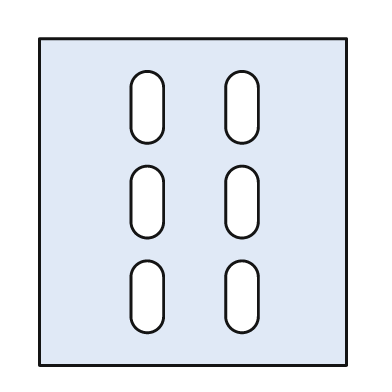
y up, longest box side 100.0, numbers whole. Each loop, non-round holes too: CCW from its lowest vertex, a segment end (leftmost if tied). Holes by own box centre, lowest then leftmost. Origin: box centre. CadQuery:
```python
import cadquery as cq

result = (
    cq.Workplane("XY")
    .moveTo(-47.0, -50.0)
    .lineTo(47.0, -50.0)
    .lineTo(47.0, 50.0)
    .lineTo(-47.0, 50.0)
    .close()
    .moveTo(-19.0, -35.0)
    .threePointArc((-14.0, -40.0), (-9.0, -35.0))
    .lineTo(-9.0, -23.0)
    .threePointArc((-14.0, -18.0), (-19.0, -23.0))
    .close()
    .moveTo(10.0, -35.0)
    .threePointArc((15.0, -40.0), (20.0, -35.0))
    .lineTo(20.0, -23.0)
    .threePointArc((15.0, -18.0), (10.0, -23.0))
    .close()
    .moveTo(-19.0, -6.0)
    .threePointArc((-14.0, -11.0), (-9.0, -6.0))
    .lineTo(-9.0, 6.0)
    .threePointArc((-14.0, 11.0), (-19.0, 6.0))
    .close()
    .moveTo(10.0, -6.0)
    .threePointArc((15.0, -11.0), (20.0, -6.0))
    .lineTo(20.0, 6.0)
    .threePointArc((15.0, 11.0), (10.0, 6.0))
    .close()
    .moveTo(-19.0, 23.0)
    .threePointArc((-14.0, 18.0), (-9.0, 23.0))
    .lineTo(-9.0, 35.0)
    .threePointArc((-14.0, 40.0), (-19.0, 35.0))
    .close()
    .moveTo(10.0, 23.0)
    .threePointArc((15.0, 18.0), (20.0, 23.0))
    .lineTo(20.0, 35.0)
    .threePointArc((15.0, 40.0), (10.0, 35.0))
    .close()
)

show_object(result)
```